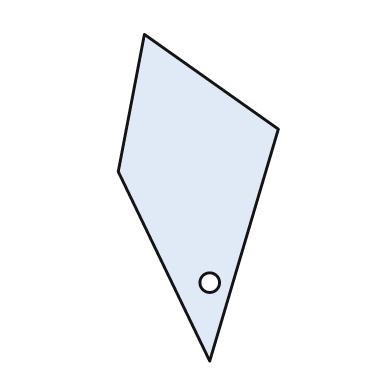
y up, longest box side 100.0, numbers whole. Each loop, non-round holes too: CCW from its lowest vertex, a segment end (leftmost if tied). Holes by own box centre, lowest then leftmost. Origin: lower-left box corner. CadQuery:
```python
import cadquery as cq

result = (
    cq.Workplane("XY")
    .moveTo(28.0, 0.0)
    .lineTo(49.0, 71.0)
    .lineTo(8.0, 100.0)
    .lineTo(0.0, 58.0)
    .close()
    .moveTo(28.0, 24.0)
    .circle(3.0)
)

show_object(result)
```